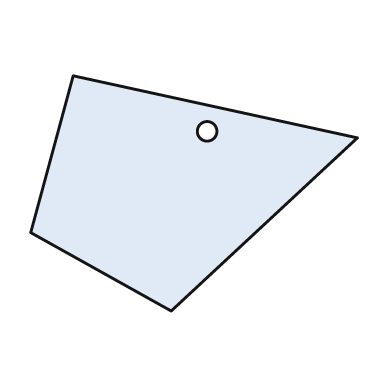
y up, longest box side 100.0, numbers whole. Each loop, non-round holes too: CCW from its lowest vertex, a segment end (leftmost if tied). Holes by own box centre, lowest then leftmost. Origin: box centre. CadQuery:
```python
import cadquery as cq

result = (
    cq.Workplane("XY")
    .moveTo(-7.0, -36.0)
    .lineTo(50.0, 17.0)
    .lineTo(-37.0, 36.0)
    .lineTo(-50.0, -12.0)
    .close()
    .moveTo(4.0, 19.0)
    .circle(3.0)
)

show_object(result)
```